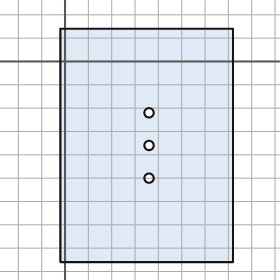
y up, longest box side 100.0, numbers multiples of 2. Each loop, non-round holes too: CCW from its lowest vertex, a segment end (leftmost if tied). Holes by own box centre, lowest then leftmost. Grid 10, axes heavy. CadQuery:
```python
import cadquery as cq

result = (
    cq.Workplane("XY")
    .moveTo(-2.0, -86.0)
    .lineTo(72.0, -86.0)
    .lineTo(72.0, 14.0)
    .lineTo(-2.0, 14.0)
    .close()
    .moveTo(36.0, -50.0)
    .circle(2.0)
    .moveTo(36.0, -36.0)
    .circle(2.0)
    .moveTo(36.0, -22.0)
    .circle(2.0)
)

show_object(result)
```